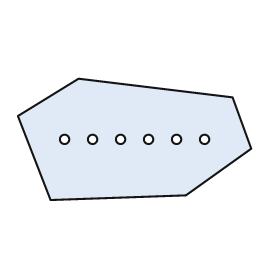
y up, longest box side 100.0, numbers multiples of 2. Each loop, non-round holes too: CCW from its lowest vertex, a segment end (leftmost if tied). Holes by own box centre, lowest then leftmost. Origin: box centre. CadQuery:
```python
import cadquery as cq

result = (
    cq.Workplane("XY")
    .moveTo(-36.0, -26.0)
    .lineTo(22.0, -24.0)
    .lineTo(50.0, -4.0)
    .lineTo(42.0, 18.0)
    .lineTo(-24.0, 26.0)
    .lineTo(-50.0, 10.0)
    .close()
    .moveTo(-30.0, 0.0)
    .circle(2.0)
    .moveTo(-18.0, 0.0)
    .circle(2.0)
    .moveTo(-6.0, 0.0)
    .circle(2.0)
    .moveTo(6.0, 0.0)
    .circle(2.0)
    .moveTo(18.0, 0.0)
    .circle(2.0)
    .moveTo(30.0, 0.0)
    .circle(2.0)
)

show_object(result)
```